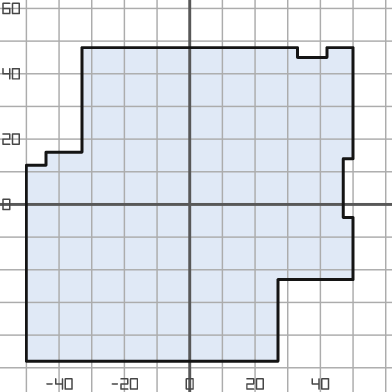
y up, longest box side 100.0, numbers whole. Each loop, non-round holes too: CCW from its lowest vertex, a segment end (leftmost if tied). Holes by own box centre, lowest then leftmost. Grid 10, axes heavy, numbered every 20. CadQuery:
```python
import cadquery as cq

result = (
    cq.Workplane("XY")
    .moveTo(-50.0, -48.0)
    .lineTo(27.0, -48.0)
    .lineTo(27.0, -23.0)
    .lineTo(50.0, -23.0)
    .lineTo(50.0, -4.0)
    .lineTo(47.0, -4.0)
    .lineTo(47.0, 14.0)
    .lineTo(50.0, 14.0)
    .lineTo(50.0, 48.0)
    .lineTo(42.0, 48.0)
    .lineTo(42.0, 45.0)
    .lineTo(33.0, 45.0)
    .lineTo(33.0, 48.0)
    .lineTo(-33.0, 48.0)
    .lineTo(-33.0, 16.0)
    .lineTo(-44.0, 16.0)
    .lineTo(-44.0, 12.0)
    .lineTo(-50.0, 12.0)
    .close()
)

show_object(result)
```